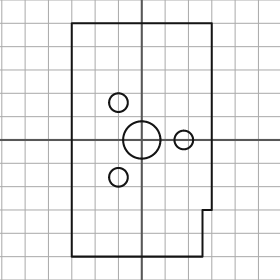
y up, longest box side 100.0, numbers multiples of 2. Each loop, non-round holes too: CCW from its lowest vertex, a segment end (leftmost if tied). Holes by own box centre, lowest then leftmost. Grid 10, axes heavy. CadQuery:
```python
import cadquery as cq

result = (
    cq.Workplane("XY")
    .moveTo(-30.0, -50.0)
    .lineTo(26.0, -50.0)
    .lineTo(26.0, -30.0)
    .lineTo(30.0, -30.0)
    .lineTo(30.0, 50.0)
    .lineTo(-30.0, 50.0)
    .close()
    .moveTo(-10.0, -16.0)
    .circle(4.0)
    .moveTo(0.0, 0.0)
    .circle(8.0)
    .moveTo(18.0, 0.0)
    .circle(4.0)
    .moveTo(-10.0, 16.0)
    .circle(4.0)
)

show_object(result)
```